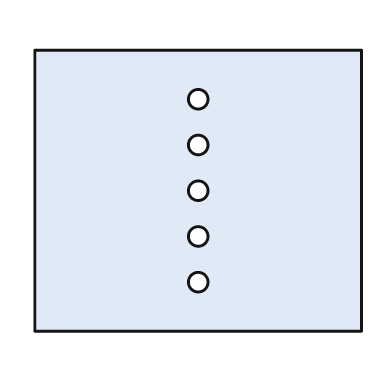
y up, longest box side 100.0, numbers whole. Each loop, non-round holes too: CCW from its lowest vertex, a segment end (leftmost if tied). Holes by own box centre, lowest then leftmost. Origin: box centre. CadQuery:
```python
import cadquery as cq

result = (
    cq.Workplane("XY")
    .moveTo(-50.0, -43.0)
    .lineTo(50.0, -43.0)
    .lineTo(50.0, 43.0)
    .lineTo(-50.0, 43.0)
    .close()
    .moveTo(0.0, -28.0)
    .circle(3.0)
    .moveTo(0.0, -14.0)
    .circle(3.0)
    .moveTo(0.0, 0.0)
    .circle(3.0)
    .moveTo(0.0, 14.0)
    .circle(3.0)
    .moveTo(0.0, 28.0)
    .circle(3.0)
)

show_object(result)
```